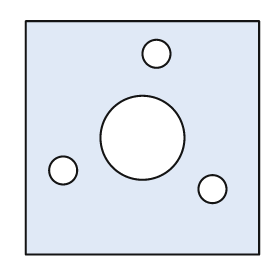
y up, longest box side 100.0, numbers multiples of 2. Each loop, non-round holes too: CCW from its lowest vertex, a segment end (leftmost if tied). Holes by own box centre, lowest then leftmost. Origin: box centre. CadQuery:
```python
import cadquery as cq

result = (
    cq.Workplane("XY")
    .moveTo(-50.0, -50.0)
    .lineTo(50.0, -50.0)
    .lineTo(50.0, 50.0)
    .lineTo(-50.0, 50.0)
    .close()
    .moveTo(30.0, -22.0)
    .circle(6.0)
    .moveTo(-34.0, -14.0)
    .circle(6.0)
    .moveTo(0.0, 0.0)
    .circle(18.0)
    .moveTo(6.0, 36.0)
    .circle(6.0)
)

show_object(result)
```